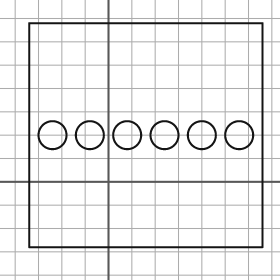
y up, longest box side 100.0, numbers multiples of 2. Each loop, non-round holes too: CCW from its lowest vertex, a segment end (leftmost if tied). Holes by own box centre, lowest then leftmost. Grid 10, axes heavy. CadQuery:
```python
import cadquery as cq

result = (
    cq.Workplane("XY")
    .moveTo(-34.0, -28.0)
    .lineTo(66.0, -28.0)
    .lineTo(66.0, 68.0)
    .lineTo(-34.0, 68.0)
    .close()
    .moveTo(-24.0, 20.0)
    .circle(6.0)
    .moveTo(-8.0, 20.0)
    .circle(6.0)
    .moveTo(8.0, 20.0)
    .circle(6.0)
    .moveTo(24.0, 20.0)
    .circle(6.0)
    .moveTo(40.0, 20.0)
    .circle(6.0)
    .moveTo(56.0, 20.0)
    .circle(6.0)
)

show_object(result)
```